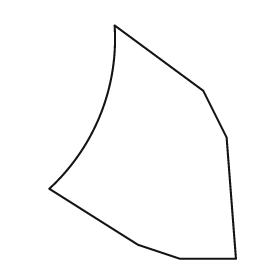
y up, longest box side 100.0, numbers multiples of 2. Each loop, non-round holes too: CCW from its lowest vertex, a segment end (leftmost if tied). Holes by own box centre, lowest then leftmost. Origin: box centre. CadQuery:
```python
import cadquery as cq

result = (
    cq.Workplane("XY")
    .moveTo(16.0, -50.0)
    .lineTo(40.0, -50.0)
    .lineTo(36.0, 2.0)
    .lineTo(26.0, 22.0)
    .lineTo(-12.0, 50.0)
    .threePointArc((-18.0, 12.0), (-40.0, -20.0))
    .lineTo(-2.0, -44.0)
    .close()
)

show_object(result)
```